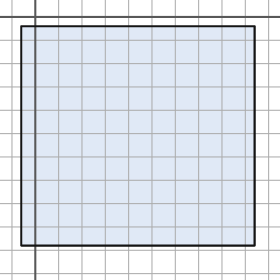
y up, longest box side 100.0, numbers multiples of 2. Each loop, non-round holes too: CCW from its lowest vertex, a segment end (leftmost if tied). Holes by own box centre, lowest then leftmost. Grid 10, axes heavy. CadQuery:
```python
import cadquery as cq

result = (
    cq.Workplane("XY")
    .moveTo(-6.0, -98.0)
    .lineTo(94.0, -98.0)
    .lineTo(94.0, -4.0)
    .lineTo(-6.0, -4.0)
    .close()
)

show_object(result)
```